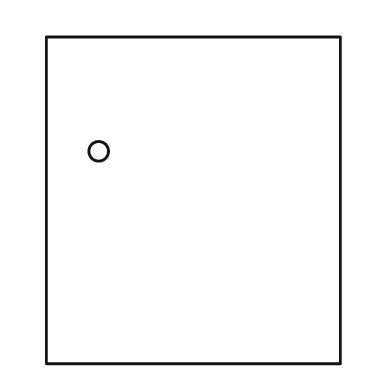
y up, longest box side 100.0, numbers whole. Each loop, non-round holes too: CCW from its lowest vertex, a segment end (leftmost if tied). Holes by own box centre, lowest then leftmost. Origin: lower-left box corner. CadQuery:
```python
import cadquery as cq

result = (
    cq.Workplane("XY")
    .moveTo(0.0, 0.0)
    .lineTo(90.0, 0.0)
    .lineTo(90.0, 100.0)
    .lineTo(0.0, 100.0)
    .close()
    .moveTo(16.0, 65.0)
    .circle(3.0)
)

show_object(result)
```